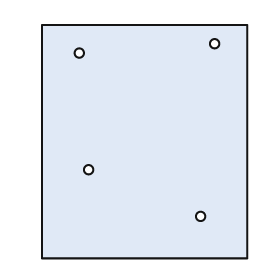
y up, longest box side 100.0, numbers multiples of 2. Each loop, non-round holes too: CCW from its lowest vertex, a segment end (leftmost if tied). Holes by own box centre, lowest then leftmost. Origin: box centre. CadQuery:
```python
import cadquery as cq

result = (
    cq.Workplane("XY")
    .moveTo(-44.0, -50.0)
    .lineTo(44.0, -50.0)
    .lineTo(44.0, 50.0)
    .lineTo(-44.0, 50.0)
    .close()
    .moveTo(24.0, -32.0)
    .circle(2.0)
    .moveTo(-24.0, -12.0)
    .circle(2.0)
    .moveTo(-28.0, 38.0)
    .circle(2.0)
    .moveTo(30.0, 42.0)
    .circle(2.0)
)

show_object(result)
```